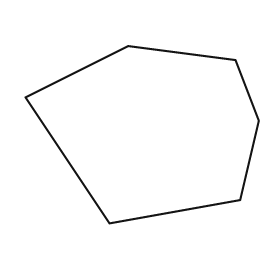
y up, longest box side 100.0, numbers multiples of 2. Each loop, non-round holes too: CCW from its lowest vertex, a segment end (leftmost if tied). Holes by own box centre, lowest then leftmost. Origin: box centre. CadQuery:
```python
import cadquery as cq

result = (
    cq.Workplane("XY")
    .moveTo(-14.0, -38.0)
    .lineTo(42.0, -28.0)
    .lineTo(50.0, 6.0)
    .lineTo(40.0, 32.0)
    .lineTo(-6.0, 38.0)
    .lineTo(-50.0, 16.0)
    .close()
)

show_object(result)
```